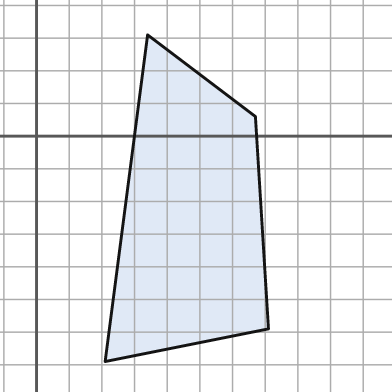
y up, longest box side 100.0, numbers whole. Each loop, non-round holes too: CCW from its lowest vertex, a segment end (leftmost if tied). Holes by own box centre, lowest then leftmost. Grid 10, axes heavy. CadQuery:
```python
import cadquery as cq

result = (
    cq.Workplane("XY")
    .moveTo(21.0, -69.0)
    .lineTo(71.0, -59.0)
    .lineTo(67.0, 6.0)
    .lineTo(34.0, 31.0)
    .close()
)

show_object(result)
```